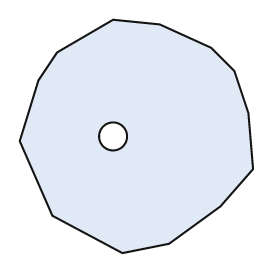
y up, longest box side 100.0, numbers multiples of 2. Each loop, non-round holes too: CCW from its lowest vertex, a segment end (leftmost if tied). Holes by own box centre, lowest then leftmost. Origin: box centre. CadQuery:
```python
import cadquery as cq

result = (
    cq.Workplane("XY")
    .moveTo(-6.0, -50.0)
    .lineTo(14.0, -46.0)
    .lineTo(36.0, -30.0)
    .lineTo(50.0, -14.0)
    .lineTo(48.0, 10.0)
    .lineTo(42.0, 28.0)
    .lineTo(32.0, 38.0)
    .lineTo(10.0, 48.0)
    .lineTo(-10.0, 50.0)
    .lineTo(-34.0, 36.0)
    .lineTo(-42.0, 24.0)
    .lineTo(-50.0, -2.0)
    .lineTo(-36.0, -34.0)
    .close()
    .moveTo(-10.0, 0.0)
    .circle(6.0)
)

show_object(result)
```